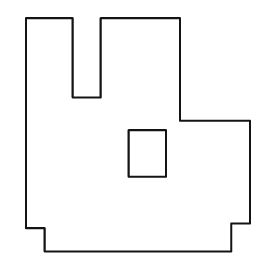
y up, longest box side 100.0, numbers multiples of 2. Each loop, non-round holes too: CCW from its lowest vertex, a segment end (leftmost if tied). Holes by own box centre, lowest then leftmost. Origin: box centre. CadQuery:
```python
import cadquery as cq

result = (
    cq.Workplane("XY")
    .moveTo(-40.0, -50.0)
    .lineTo(40.0, -50.0)
    .lineTo(40.0, -38.0)
    .lineTo(48.0, -38.0)
    .lineTo(48.0, 6.0)
    .lineTo(18.0, 6.0)
    .lineTo(18.0, 50.0)
    .lineTo(-16.0, 50.0)
    .lineTo(-16.0, 16.0)
    .lineTo(-28.0, 16.0)
    .lineTo(-28.0, 50.0)
    .lineTo(-48.0, 50.0)
    .lineTo(-48.0, -40.0)
    .lineTo(-40.0, -40.0)
    .close()
    .moveTo(-4.0, -18.0)
    .lineTo(12.0, -18.0)
    .lineTo(12.0, 2.0)
    .lineTo(-4.0, 2.0)
    .close()
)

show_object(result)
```